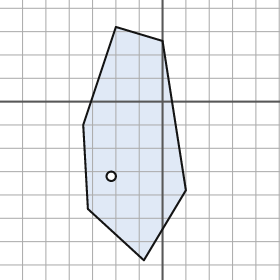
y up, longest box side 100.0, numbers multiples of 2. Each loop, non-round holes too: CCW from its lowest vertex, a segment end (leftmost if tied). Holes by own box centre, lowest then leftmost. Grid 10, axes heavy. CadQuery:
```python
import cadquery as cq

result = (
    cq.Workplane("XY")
    .moveTo(-8.0, -68.0)
    .lineTo(10.0, -38.0)
    .lineTo(0.0, 26.0)
    .lineTo(-20.0, 32.0)
    .lineTo(-34.0, -10.0)
    .lineTo(-32.0, -46.0)
    .close()
    .moveTo(-22.0, -32.0)
    .circle(2.0)
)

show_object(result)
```